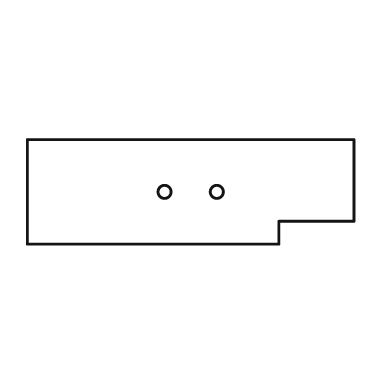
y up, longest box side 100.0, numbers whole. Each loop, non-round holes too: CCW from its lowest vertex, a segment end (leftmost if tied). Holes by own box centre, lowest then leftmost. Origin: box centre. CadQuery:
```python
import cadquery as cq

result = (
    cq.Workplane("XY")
    .moveTo(-50.0, -16.0)
    .lineTo(27.0, -16.0)
    .lineTo(27.0, -9.0)
    .lineTo(50.0, -9.0)
    .lineTo(50.0, 16.0)
    .lineTo(-50.0, 16.0)
    .close()
    .moveTo(-8.0, 0.0)
    .circle(2.0)
    .moveTo(8.0, 0.0)
    .circle(2.0)
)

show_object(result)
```